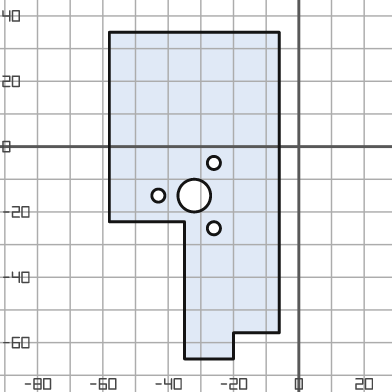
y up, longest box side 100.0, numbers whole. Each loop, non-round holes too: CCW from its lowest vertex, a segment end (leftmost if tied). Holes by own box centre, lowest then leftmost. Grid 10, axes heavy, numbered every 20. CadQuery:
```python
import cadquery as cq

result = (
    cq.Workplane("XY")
    .moveTo(-35.0, -65.0)
    .lineTo(-20.0, -65.0)
    .lineTo(-20.0, -57.0)
    .lineTo(-6.0, -57.0)
    .lineTo(-6.0, 35.0)
    .lineTo(-58.0, 35.0)
    .lineTo(-58.0, -23.0)
    .lineTo(-35.0, -23.0)
    .close()
    .moveTo(-26.0, -25.0)
    .circle(2.0)
    .moveTo(-43.0, -15.0)
    .circle(2.0)
    .moveTo(-32.0, -15.0)
    .circle(5.0)
    .moveTo(-26.0, -5.0)
    .circle(2.0)
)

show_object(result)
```